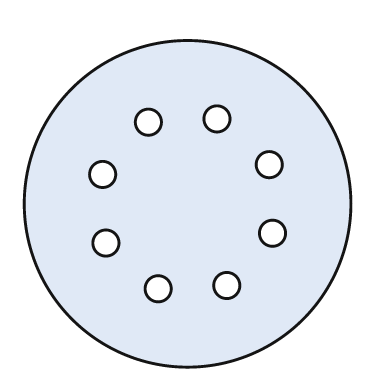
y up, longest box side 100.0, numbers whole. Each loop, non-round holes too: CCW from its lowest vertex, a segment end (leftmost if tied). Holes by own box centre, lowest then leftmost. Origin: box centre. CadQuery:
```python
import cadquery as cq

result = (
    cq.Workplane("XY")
    .moveTo(0.0, 0.0)
    .circle(50.0)
    .moveTo(-9.0, -26.0)
    .circle(4.0)
    .moveTo(12.0, -25.0)
    .circle(4.0)
    .moveTo(-25.0, -12.0)
    .circle(4.0)
    .moveTo(26.0, -9.0)
    .circle(4.0)
    .moveTo(-26.0, 9.0)
    .circle(4.0)
    .moveTo(25.0, 12.0)
    .circle(4.0)
    .moveTo(-12.0, 25.0)
    .circle(4.0)
    .moveTo(9.0, 26.0)
    .circle(4.0)
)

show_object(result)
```